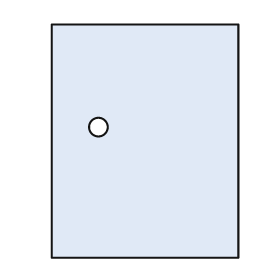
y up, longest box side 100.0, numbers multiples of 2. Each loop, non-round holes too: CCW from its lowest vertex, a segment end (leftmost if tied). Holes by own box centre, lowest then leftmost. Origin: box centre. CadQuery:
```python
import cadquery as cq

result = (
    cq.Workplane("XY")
    .moveTo(-40.0, -50.0)
    .lineTo(40.0, -50.0)
    .lineTo(40.0, 50.0)
    .lineTo(-40.0, 50.0)
    .close()
    .moveTo(-20.0, 6.0)
    .circle(4.0)
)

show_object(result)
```